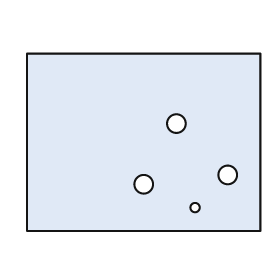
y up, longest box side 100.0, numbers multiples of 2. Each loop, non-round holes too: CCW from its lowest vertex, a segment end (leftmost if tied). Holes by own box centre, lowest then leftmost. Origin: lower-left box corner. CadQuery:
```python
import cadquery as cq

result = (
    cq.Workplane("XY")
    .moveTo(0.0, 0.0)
    .lineTo(100.0, 0.0)
    .lineTo(100.0, 76.0)
    .lineTo(0.0, 76.0)
    .close()
    .moveTo(72.0, 10.0)
    .circle(2.0)
    .moveTo(50.0, 20.0)
    .circle(4.0)
    .moveTo(86.0, 24.0)
    .circle(4.0)
    .moveTo(64.0, 46.0)
    .circle(4.0)
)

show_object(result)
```